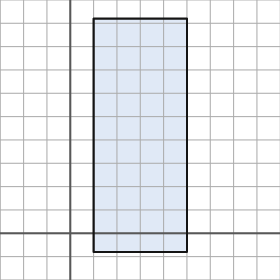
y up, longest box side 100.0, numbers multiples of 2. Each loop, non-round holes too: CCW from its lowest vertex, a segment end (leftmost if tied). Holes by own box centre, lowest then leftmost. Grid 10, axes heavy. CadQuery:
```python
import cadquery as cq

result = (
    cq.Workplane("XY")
    .moveTo(10.0, -8.0)
    .lineTo(50.0, -8.0)
    .lineTo(50.0, 92.0)
    .lineTo(10.0, 92.0)
    .close()
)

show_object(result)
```